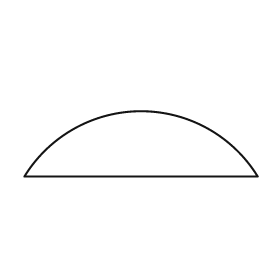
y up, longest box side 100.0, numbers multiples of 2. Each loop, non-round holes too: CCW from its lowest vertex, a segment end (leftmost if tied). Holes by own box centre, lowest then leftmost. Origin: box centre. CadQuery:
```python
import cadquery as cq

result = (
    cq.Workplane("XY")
    .moveTo(-50.0, -14.0)
    .lineTo(50.0, -14.0)
    .threePointArc((0.0, 14.0), (-50.0, -14.0))
    .close()
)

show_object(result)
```